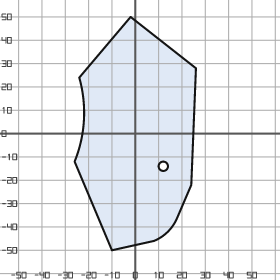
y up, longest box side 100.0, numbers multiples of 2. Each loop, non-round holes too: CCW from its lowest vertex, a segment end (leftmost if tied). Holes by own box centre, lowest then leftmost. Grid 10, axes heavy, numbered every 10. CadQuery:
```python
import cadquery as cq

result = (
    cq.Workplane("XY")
    .moveTo(-10.0, -50.0)
    .lineTo(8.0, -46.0)
    .threePointArc((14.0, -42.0), (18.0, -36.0))
    .lineTo(24.0, -22.0)
    .lineTo(26.0, 28.0)
    .lineTo(-2.0, 50.0)
    .lineTo(-24.0, 24.0)
    .threePointArc((-22.0, 6.0), (-26.0, -12.0))
    .close()
    .moveTo(12.0, -14.0)
    .circle(2.0)
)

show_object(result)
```